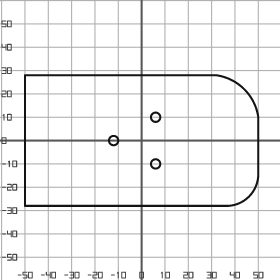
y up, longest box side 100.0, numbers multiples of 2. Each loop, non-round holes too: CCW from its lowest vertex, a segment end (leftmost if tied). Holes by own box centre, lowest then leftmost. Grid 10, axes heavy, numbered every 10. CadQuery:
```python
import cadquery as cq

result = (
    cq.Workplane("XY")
    .moveTo(-50.0, -28.0)
    .lineTo(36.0, -28.0)
    .threePointArc((46.0, -24.0), (50.0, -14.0))
    .lineTo(50.0, 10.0)
    .threePointArc((44.0, 22.0), (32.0, 28.0))
    .lineTo(-50.0, 28.0)
    .close()
    .moveTo(6.0, -10.0)
    .circle(2.0)
    .moveTo(-12.0, 0.0)
    .circle(2.0)
    .moveTo(6.0, 10.0)
    .circle(2.0)
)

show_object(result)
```